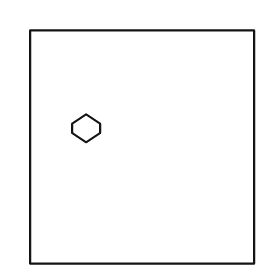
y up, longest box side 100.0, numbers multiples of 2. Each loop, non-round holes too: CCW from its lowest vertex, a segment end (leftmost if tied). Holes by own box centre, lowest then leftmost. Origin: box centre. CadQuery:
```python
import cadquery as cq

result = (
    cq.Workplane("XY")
    .moveTo(-48.0, -50.0)
    .lineTo(48.0, -50.0)
    .lineTo(48.0, 50.0)
    .lineTo(-48.0, 50.0)
    .close()
    .moveTo(-24.0, 2.0)
    .lineTo(-18.0, 6.0)
    .lineTo(-18.0, 10.0)
    .lineTo(-24.0, 14.0)
    .lineTo(-30.0, 10.0)
    .lineTo(-30.0, 6.0)
    .close()
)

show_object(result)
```